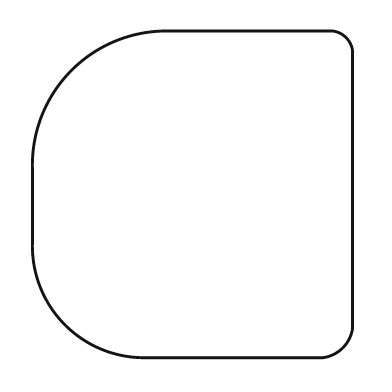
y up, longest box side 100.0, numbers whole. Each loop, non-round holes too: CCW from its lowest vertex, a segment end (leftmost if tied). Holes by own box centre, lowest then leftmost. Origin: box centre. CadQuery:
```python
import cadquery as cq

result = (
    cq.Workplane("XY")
    .moveTo(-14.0, -50.0)
    .lineTo(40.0, -50.0)
    .threePointArc((46.0, -47.0), (49.0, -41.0))
    .lineTo(49.0, 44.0)
    .threePointArc((47.0, 48.0), (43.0, 50.0))
    .lineTo(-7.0, 50.0)
    .threePointArc((-37.0, 38.0), (-49.0, 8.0))
    .lineTo(-49.0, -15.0)
    .threePointArc((-39.0, -40.0), (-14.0, -50.0))
    .close()
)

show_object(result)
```